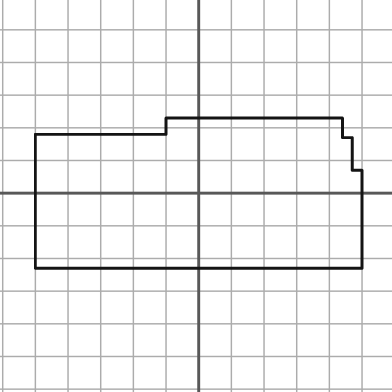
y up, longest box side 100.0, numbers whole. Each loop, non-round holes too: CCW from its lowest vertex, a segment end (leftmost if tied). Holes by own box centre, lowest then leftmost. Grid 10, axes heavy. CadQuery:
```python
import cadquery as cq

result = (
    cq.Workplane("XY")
    .moveTo(-50.0, -23.0)
    .lineTo(50.0, -23.0)
    .lineTo(50.0, 7.0)
    .lineTo(47.0, 7.0)
    .lineTo(47.0, 17.0)
    .lineTo(44.0, 17.0)
    .lineTo(44.0, 23.0)
    .lineTo(-10.0, 23.0)
    .lineTo(-10.0, 18.0)
    .lineTo(-50.0, 18.0)
    .close()
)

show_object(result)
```